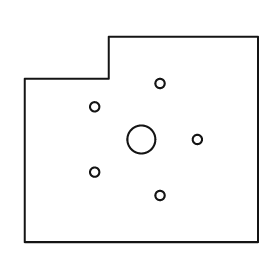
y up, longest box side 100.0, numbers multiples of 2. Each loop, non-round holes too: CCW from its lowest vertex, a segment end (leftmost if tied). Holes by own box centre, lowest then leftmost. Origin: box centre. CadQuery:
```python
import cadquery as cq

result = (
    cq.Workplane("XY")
    .moveTo(-50.0, -44.0)
    .lineTo(50.0, -44.0)
    .lineTo(50.0, 44.0)
    .lineTo(-14.0, 44.0)
    .lineTo(-14.0, 26.0)
    .lineTo(-50.0, 26.0)
    .close()
    .moveTo(8.0, -24.0)
    .circle(2.0)
    .moveTo(-20.0, -14.0)
    .circle(2.0)
    .moveTo(0.0, 0.0)
    .circle(6.0)
    .moveTo(24.0, 0.0)
    .circle(2.0)
    .moveTo(-20.0, 14.0)
    .circle(2.0)
    .moveTo(8.0, 24.0)
    .circle(2.0)
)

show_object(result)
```